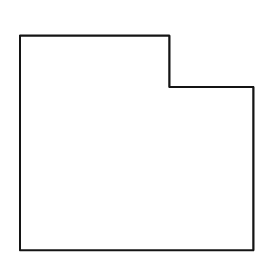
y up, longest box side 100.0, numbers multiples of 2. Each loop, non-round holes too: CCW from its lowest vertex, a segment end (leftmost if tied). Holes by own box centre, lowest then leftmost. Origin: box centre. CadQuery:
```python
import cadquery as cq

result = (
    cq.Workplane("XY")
    .moveTo(-50.0, -46.0)
    .lineTo(50.0, -46.0)
    .lineTo(50.0, 24.0)
    .lineTo(14.0, 24.0)
    .lineTo(14.0, 46.0)
    .lineTo(-50.0, 46.0)
    .close()
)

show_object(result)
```